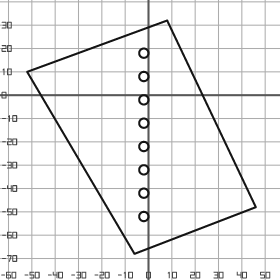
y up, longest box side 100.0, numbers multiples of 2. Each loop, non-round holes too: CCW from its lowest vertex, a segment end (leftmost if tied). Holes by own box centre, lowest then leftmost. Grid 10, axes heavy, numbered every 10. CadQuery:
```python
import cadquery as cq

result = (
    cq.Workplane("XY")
    .moveTo(-6.0, -68.0)
    .lineTo(46.0, -48.0)
    .lineTo(8.0, 32.0)
    .lineTo(-52.0, 10.0)
    .close()
    .moveTo(-2.0, -52.0)
    .circle(2.0)
    .moveTo(-2.0, -42.0)
    .circle(2.0)
    .moveTo(-2.0, -32.0)
    .circle(2.0)
    .moveTo(-2.0, -22.0)
    .circle(2.0)
    .moveTo(-2.0, -12.0)
    .circle(2.0)
    .moveTo(-2.0, -2.0)
    .circle(2.0)
    .moveTo(-2.0, 8.0)
    .circle(2.0)
    .moveTo(-2.0, 18.0)
    .circle(2.0)
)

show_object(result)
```